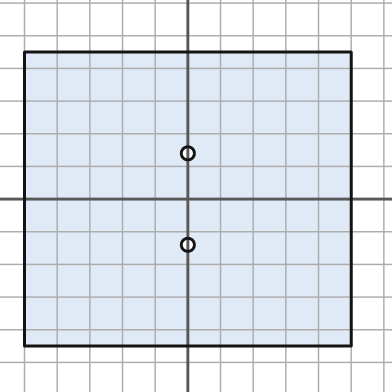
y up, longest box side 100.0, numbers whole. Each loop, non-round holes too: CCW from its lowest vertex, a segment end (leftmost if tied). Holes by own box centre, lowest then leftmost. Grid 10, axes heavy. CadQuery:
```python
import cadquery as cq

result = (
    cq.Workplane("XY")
    .moveTo(-50.0, -45.0)
    .lineTo(50.0, -45.0)
    .lineTo(50.0, 45.0)
    .lineTo(-50.0, 45.0)
    .close()
    .moveTo(0.0, -14.0)
    .circle(2.0)
    .moveTo(0.0, 14.0)
    .circle(2.0)
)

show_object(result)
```